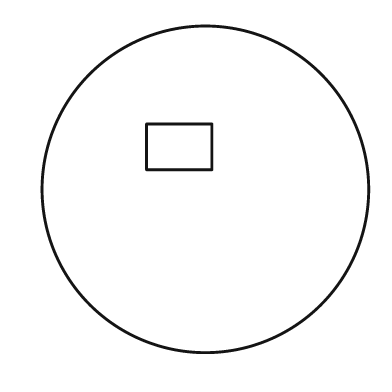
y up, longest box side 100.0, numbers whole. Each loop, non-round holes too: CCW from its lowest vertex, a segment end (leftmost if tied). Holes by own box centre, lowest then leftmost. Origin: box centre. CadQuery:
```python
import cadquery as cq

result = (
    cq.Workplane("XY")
    .moveTo(0.0, 0.0)
    .circle(50.0)
    .moveTo(-18.0, 6.0)
    .lineTo(2.0, 6.0)
    .lineTo(2.0, 20.0)
    .lineTo(-18.0, 20.0)
    .close()
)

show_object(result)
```